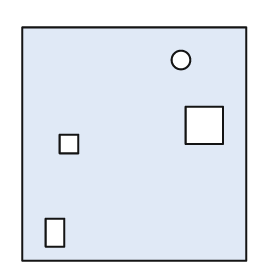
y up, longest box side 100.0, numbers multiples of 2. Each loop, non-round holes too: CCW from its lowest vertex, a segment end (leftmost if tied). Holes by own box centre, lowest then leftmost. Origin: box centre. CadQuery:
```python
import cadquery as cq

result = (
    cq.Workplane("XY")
    .moveTo(-48.0, -50.0)
    .lineTo(48.0, -50.0)
    .lineTo(48.0, 50.0)
    .lineTo(-48.0, 50.0)
    .close()
    .moveTo(-38.0, -44.0)
    .lineTo(-30.0, -44.0)
    .lineTo(-30.0, -32.0)
    .lineTo(-38.0, -32.0)
    .close()
    .moveTo(-32.0, -4.0)
    .lineTo(-24.0, -4.0)
    .lineTo(-24.0, 4.0)
    .lineTo(-32.0, 4.0)
    .close()
    .moveTo(22.0, 0.0)
    .lineTo(38.0, 0.0)
    .lineTo(38.0, 16.0)
    .lineTo(22.0, 16.0)
    .close()
    .moveTo(20.0, 36.0)
    .circle(4.0)
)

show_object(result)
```